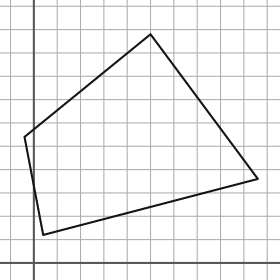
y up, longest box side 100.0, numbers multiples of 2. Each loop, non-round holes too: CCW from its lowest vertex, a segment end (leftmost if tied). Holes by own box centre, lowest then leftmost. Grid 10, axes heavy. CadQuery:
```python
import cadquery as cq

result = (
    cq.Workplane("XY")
    .moveTo(4.0, 12.0)
    .lineTo(96.0, 36.0)
    .lineTo(50.0, 98.0)
    .lineTo(-4.0, 54.0)
    .close()
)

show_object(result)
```